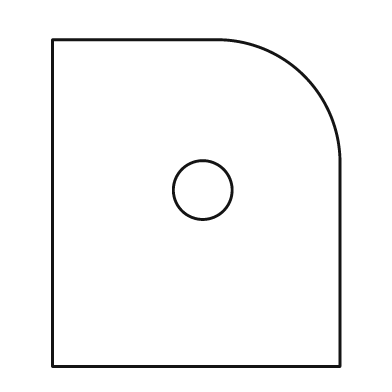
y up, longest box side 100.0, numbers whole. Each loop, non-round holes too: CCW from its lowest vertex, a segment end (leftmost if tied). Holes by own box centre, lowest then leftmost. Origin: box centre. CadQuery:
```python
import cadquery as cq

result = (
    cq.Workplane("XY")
    .moveTo(-44.0, -50.0)
    .lineTo(44.0, -50.0)
    .lineTo(44.0, 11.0)
    .threePointArc((33.0, 39.0), (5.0, 50.0))
    .lineTo(-44.0, 50.0)
    .close()
    .moveTo(2.0, 4.0)
    .circle(9.0)
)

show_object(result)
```